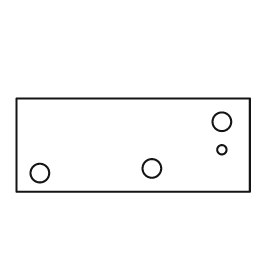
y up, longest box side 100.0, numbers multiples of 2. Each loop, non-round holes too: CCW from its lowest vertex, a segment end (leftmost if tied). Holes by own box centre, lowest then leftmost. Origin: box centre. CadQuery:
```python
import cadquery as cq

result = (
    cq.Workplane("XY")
    .moveTo(-50.0, -20.0)
    .lineTo(50.0, -20.0)
    .lineTo(50.0, 20.0)
    .lineTo(-50.0, 20.0)
    .close()
    .moveTo(-40.0, -12.0)
    .circle(4.0)
    .moveTo(8.0, -10.0)
    .circle(4.0)
    .moveTo(38.0, -2.0)
    .circle(2.0)
    .moveTo(38.0, 10.0)
    .circle(4.0)
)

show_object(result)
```